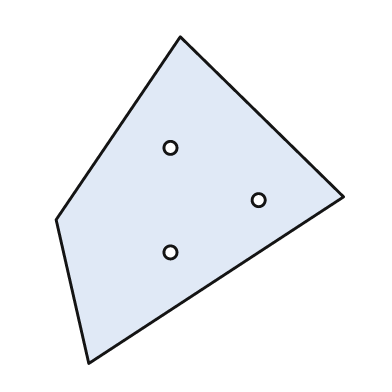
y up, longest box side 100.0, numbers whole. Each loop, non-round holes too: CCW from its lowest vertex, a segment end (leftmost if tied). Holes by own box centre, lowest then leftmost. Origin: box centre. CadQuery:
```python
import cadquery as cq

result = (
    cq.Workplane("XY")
    .moveTo(-34.0, -50.0)
    .lineTo(44.0, 1.0)
    .lineTo(-6.0, 50.0)
    .lineTo(-44.0, -6.0)
    .close()
    .moveTo(-9.0, -16.0)
    .circle(2.0)
    .moveTo(18.0, 0.0)
    .circle(2.0)
    .moveTo(-9.0, 16.0)
    .circle(2.0)
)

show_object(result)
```